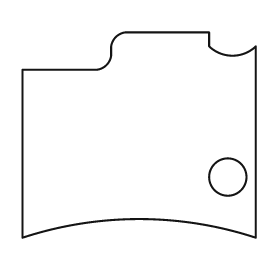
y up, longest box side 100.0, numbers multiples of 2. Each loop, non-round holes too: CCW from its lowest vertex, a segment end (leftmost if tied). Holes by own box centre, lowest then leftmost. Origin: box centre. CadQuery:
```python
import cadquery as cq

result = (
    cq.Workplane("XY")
    .moveTo(-50.0, -44.0)
    .threePointArc((0.0, -36.0), (50.0, -44.0))
    .lineTo(50.0, 38.0)
    .threePointArc((40.0, 34.0), (30.0, 38.0))
    .lineTo(30.0, 44.0)
    .lineTo(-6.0, 44.0)
    .threePointArc((-10.0, 42.0), (-12.0, 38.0))
    .lineTo(-12.0, 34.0)
    .threePointArc((-14.0, 30.0), (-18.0, 28.0))
    .lineTo(-50.0, 28.0)
    .close()
    .moveTo(38.0, -18.0)
    .circle(8.0)
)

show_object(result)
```